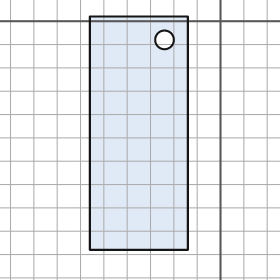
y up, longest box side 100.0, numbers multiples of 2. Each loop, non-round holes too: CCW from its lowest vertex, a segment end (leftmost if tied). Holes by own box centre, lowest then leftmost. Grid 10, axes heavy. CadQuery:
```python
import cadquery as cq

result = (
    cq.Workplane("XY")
    .moveTo(-56.0, -98.0)
    .lineTo(-14.0, -98.0)
    .lineTo(-14.0, 2.0)
    .lineTo(-56.0, 2.0)
    .close()
    .moveTo(-24.0, -8.0)
    .circle(4.0)
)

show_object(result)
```